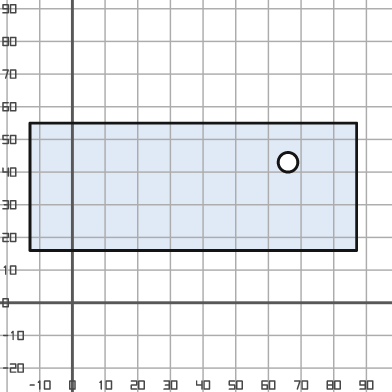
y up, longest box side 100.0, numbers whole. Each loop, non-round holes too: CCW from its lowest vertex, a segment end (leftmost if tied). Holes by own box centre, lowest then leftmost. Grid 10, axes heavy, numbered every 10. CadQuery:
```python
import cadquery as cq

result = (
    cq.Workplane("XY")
    .moveTo(-13.0, 16.0)
    .lineTo(87.0, 16.0)
    .lineTo(87.0, 55.0)
    .lineTo(-13.0, 55.0)
    .close()
    .moveTo(66.0, 43.0)
    .circle(3.0)
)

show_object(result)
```